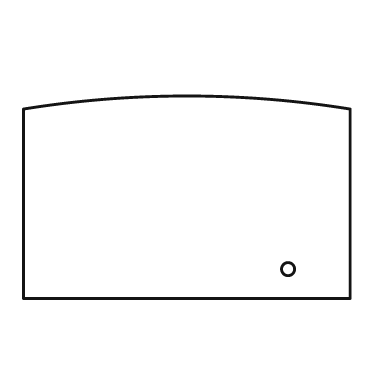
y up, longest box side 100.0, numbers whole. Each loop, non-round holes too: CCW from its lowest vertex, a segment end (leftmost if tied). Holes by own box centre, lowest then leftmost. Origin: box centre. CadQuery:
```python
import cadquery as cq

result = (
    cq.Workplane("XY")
    .moveTo(-50.0, -31.0)
    .lineTo(50.0, -31.0)
    .lineTo(50.0, 27.0)
    .threePointArc((0.0, 31.0), (-50.0, 27.0))
    .close()
    .moveTo(31.0, -22.0)
    .circle(2.0)
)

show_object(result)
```